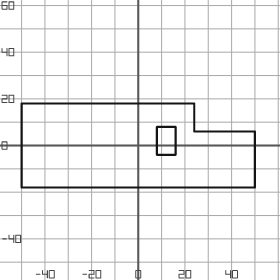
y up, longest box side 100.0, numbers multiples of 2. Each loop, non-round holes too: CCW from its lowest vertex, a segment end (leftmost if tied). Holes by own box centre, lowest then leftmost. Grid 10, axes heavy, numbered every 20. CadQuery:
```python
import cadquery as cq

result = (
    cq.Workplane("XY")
    .moveTo(-50.0, -18.0)
    .lineTo(50.0, -18.0)
    .lineTo(50.0, 6.0)
    .lineTo(24.0, 6.0)
    .lineTo(24.0, 18.0)
    .lineTo(-50.0, 18.0)
    .close()
    .moveTo(8.0, -4.0)
    .lineTo(16.0, -4.0)
    .lineTo(16.0, 8.0)
    .lineTo(8.0, 8.0)
    .close()
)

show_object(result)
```